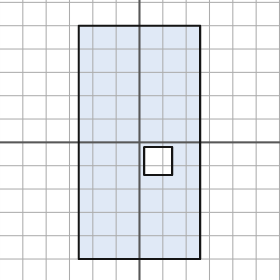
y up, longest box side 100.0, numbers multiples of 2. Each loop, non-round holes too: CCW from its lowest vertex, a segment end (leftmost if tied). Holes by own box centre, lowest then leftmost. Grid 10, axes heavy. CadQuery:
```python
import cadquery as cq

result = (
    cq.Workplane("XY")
    .moveTo(-26.0, -50.0)
    .lineTo(26.0, -50.0)
    .lineTo(26.0, 50.0)
    .lineTo(-26.0, 50.0)
    .close()
    .moveTo(2.0, -14.0)
    .lineTo(14.0, -14.0)
    .lineTo(14.0, -2.0)
    .lineTo(2.0, -2.0)
    .close()
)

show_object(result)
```